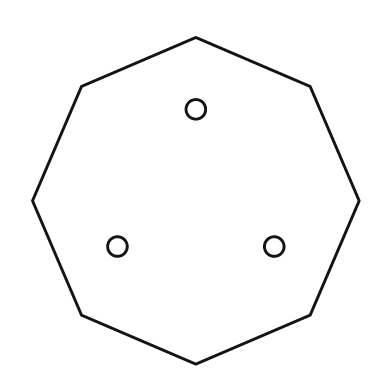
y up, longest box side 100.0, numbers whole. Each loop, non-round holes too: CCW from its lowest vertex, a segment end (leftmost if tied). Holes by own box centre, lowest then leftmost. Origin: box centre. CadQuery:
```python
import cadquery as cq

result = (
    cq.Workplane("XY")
    .moveTo(0.0, -50.0)
    .lineTo(35.0, -35.0)
    .lineTo(50.0, 0.0)
    .lineTo(35.0, 35.0)
    .lineTo(0.0, 50.0)
    .lineTo(-35.0, 35.0)
    .lineTo(-50.0, 0.0)
    .lineTo(-35.0, -35.0)
    .close()
    .moveTo(-24.0, -14.0)
    .circle(3.0)
    .moveTo(24.0, -14.0)
    .circle(3.0)
    .moveTo(0.0, 28.0)
    .circle(3.0)
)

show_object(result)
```